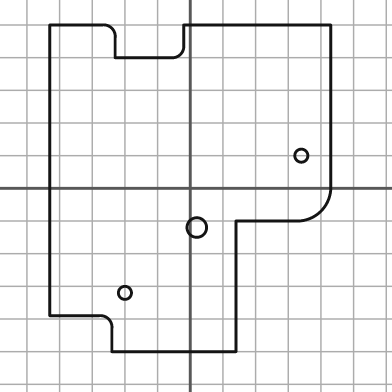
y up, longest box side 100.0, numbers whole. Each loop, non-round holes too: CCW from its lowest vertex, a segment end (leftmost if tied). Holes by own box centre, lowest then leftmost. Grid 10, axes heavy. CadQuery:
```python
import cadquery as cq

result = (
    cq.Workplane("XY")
    .moveTo(-24.0, -50.0)
    .lineTo(14.0, -50.0)
    .lineTo(14.0, -10.0)
    .lineTo(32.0, -10.0)
    .threePointArc((40.0, -7.0), (43.0, 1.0))
    .lineTo(43.0, 50.0)
    .lineTo(-2.0, 50.0)
    .lineTo(-2.0, 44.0)
    .threePointArc((-3.0, 41.0), (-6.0, 40.0))
    .lineTo(-23.0, 40.0)
    .lineTo(-23.0, 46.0)
    .threePointArc((-24.0, 49.0), (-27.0, 50.0))
    .lineTo(-43.0, 50.0)
    .lineTo(-43.0, -39.0)
    .lineTo(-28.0, -39.0)
    .threePointArc((-25.0, -40.0), (-24.0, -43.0))
    .close()
    .moveTo(-20.0, -32.0)
    .circle(2.0)
    .moveTo(2.0, -12.0)
    .circle(3.0)
    .moveTo(34.0, 10.0)
    .circle(2.0)
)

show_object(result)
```